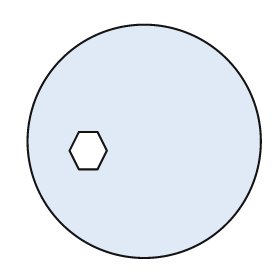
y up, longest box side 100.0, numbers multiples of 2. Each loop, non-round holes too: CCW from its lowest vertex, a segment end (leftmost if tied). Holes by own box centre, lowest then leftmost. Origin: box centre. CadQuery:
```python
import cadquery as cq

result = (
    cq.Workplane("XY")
    .moveTo(0.0, 0.0)
    .circle(50.0)
    .moveTo(-28.0, -12.0)
    .lineTo(-20.0, -12.0)
    .lineTo(-16.0, -4.0)
    .lineTo(-20.0, 4.0)
    .lineTo(-28.0, 4.0)
    .lineTo(-32.0, -4.0)
    .close()
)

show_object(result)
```